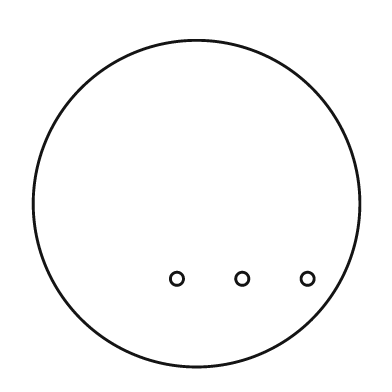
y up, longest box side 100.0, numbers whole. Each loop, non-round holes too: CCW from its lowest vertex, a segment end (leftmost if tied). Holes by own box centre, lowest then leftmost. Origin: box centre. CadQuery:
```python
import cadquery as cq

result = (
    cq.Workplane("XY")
    .moveTo(0.0, 0.0)
    .circle(50.0)
    .moveTo(-6.0, -23.0)
    .circle(2.0)
    .moveTo(14.0, -23.0)
    .circle(2.0)
    .moveTo(34.0, -23.0)
    .circle(2.0)
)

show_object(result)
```